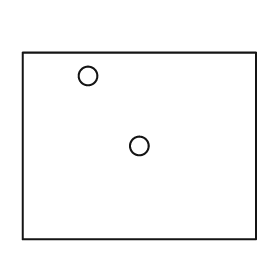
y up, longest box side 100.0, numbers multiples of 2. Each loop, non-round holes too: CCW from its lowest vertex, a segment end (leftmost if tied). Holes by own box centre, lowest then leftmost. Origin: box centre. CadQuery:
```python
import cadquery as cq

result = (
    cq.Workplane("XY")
    .moveTo(-50.0, -40.0)
    .lineTo(50.0, -40.0)
    .lineTo(50.0, 40.0)
    .lineTo(-50.0, 40.0)
    .close()
    .moveTo(0.0, 0.0)
    .circle(4.0)
    .moveTo(-22.0, 30.0)
    .circle(4.0)
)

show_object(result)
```